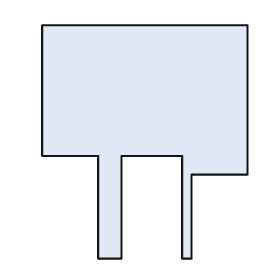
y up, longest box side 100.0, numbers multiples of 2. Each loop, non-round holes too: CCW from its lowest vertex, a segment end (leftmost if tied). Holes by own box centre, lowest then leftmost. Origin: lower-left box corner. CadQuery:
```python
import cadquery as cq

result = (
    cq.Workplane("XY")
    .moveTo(24.0, 0.0)
    .lineTo(34.0, 0.0)
    .lineTo(34.0, 44.0)
    .lineTo(60.0, 44.0)
    .lineTo(60.0, 0.0)
    .lineTo(64.0, 0.0)
    .lineTo(64.0, 36.0)
    .lineTo(88.0, 36.0)
    .lineTo(88.0, 100.0)
    .lineTo(0.0, 100.0)
    .lineTo(0.0, 44.0)
    .lineTo(24.0, 44.0)
    .close()
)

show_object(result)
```